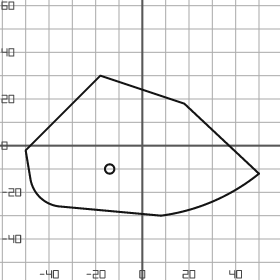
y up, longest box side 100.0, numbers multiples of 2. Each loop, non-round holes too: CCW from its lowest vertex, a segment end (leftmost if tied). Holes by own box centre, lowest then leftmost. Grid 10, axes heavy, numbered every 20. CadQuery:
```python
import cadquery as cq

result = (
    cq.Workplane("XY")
    .moveTo(8.0, -30.0)
    .threePointArc((30.0, -24.0), (50.0, -12.0))
    .lineTo(18.0, 18.0)
    .lineTo(-18.0, 30.0)
    .lineTo(-50.0, -2.0)
    .lineTo(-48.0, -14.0)
    .threePointArc((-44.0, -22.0), (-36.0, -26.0))
    .close()
    .moveTo(-14.0, -10.0)
    .circle(2.0)
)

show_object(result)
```